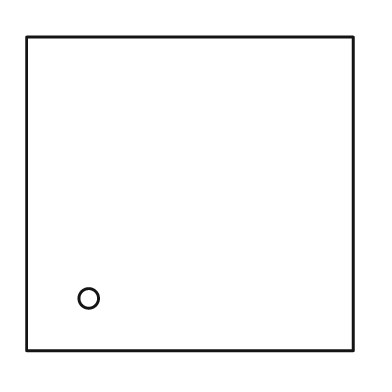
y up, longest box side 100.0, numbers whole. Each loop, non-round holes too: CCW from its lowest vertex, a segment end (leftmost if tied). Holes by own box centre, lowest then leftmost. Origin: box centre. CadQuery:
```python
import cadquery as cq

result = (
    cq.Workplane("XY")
    .moveTo(-50.0, -48.0)
    .lineTo(50.0, -48.0)
    .lineTo(50.0, 48.0)
    .lineTo(-50.0, 48.0)
    .close()
    .moveTo(-31.0, -32.0)
    .circle(3.0)
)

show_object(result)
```